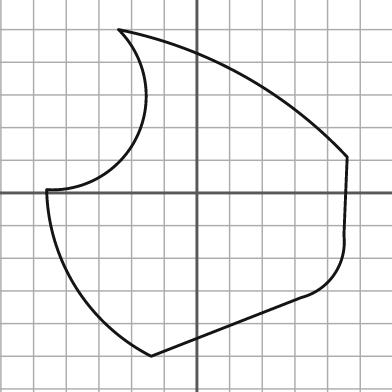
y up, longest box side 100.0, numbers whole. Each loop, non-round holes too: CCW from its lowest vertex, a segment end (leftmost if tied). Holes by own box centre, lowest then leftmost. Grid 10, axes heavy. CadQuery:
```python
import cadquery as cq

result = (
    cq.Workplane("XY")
    .moveTo(-14.0, -50.0)
    .lineTo(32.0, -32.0)
    .threePointArc((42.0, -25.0), (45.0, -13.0))
    .lineTo(46.0, 11.0)
    .threePointArc((14.0, 36.0), (-24.0, 50.0))
    .threePointArc((-18.0, 18.0), (-46.0, 1.0))
    .threePointArc((-37.0, -29.0), (-14.0, -50.0))
    .close()
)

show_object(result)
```